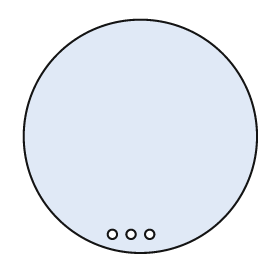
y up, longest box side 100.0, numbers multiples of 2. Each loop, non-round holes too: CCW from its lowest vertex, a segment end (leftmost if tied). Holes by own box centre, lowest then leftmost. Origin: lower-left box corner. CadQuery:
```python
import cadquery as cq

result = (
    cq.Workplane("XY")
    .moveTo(50.0, 50.0)
    .circle(50.0)
    .moveTo(38.0, 8.0)
    .circle(2.0)
    .moveTo(46.0, 8.0)
    .circle(2.0)
    .moveTo(54.0, 8.0)
    .circle(2.0)
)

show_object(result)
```